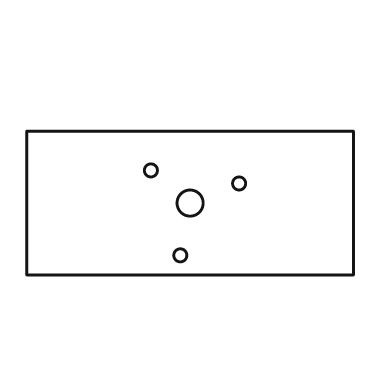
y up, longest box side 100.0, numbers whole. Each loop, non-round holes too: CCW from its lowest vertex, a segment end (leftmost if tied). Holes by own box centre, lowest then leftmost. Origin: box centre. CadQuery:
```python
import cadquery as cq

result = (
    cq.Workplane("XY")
    .moveTo(-50.0, -22.0)
    .lineTo(50.0, -22.0)
    .lineTo(50.0, 22.0)
    .lineTo(-50.0, 22.0)
    .close()
    .moveTo(-3.0, -16.0)
    .circle(2.0)
    .moveTo(0.0, 0.0)
    .circle(4.0)
    .moveTo(15.0, 6.0)
    .circle(2.0)
    .moveTo(-12.0, 10.0)
    .circle(2.0)
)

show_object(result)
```